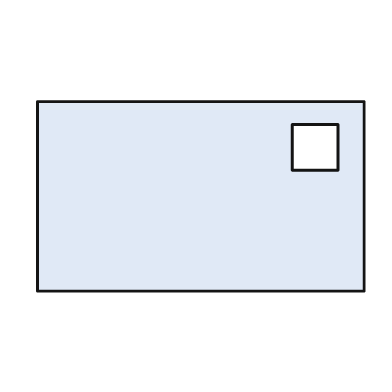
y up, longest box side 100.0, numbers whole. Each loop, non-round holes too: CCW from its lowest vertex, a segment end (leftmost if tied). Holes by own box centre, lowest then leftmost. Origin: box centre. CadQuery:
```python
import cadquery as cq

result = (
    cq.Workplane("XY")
    .moveTo(-50.0, -29.0)
    .lineTo(50.0, -29.0)
    .lineTo(50.0, 29.0)
    .lineTo(-50.0, 29.0)
    .close()
    .moveTo(28.0, 8.0)
    .lineTo(42.0, 8.0)
    .lineTo(42.0, 22.0)
    .lineTo(28.0, 22.0)
    .close()
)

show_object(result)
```